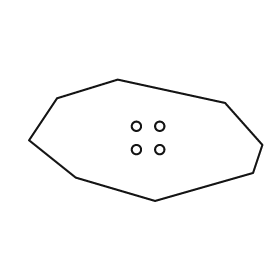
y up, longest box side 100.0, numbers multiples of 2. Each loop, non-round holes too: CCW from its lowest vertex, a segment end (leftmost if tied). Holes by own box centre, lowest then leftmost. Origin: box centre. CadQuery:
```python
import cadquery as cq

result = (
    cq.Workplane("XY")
    .moveTo(4.0, -26.0)
    .lineTo(46.0, -14.0)
    .lineTo(50.0, -2.0)
    .lineTo(34.0, 16.0)
    .lineTo(-12.0, 26.0)
    .lineTo(-38.0, 18.0)
    .lineTo(-50.0, 0.0)
    .lineTo(-30.0, -16.0)
    .close()
    .moveTo(-4.0, -4.0)
    .circle(2.0)
    .moveTo(6.0, -4.0)
    .circle(2.0)
    .moveTo(-4.0, 6.0)
    .circle(2.0)
    .moveTo(6.0, 6.0)
    .circle(2.0)
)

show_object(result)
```